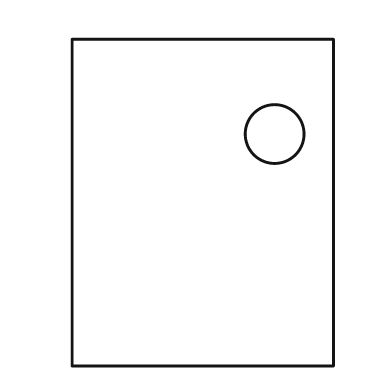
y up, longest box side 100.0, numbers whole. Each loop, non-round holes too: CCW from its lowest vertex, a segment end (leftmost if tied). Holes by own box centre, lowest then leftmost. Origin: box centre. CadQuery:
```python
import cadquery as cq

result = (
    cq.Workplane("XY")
    .moveTo(-40.0, -50.0)
    .lineTo(40.0, -50.0)
    .lineTo(40.0, 50.0)
    .lineTo(-40.0, 50.0)
    .close()
    .moveTo(22.0, 21.0)
    .circle(9.0)
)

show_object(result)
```